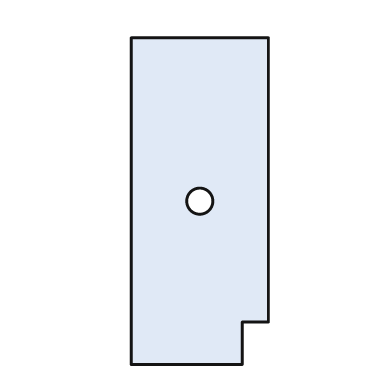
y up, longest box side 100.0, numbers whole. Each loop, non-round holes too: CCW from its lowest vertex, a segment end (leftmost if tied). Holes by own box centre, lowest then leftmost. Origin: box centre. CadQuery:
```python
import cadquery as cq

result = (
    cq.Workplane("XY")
    .moveTo(-21.0, -50.0)
    .lineTo(13.0, -50.0)
    .lineTo(13.0, -37.0)
    .lineTo(21.0, -37.0)
    .lineTo(21.0, 50.0)
    .lineTo(-21.0, 50.0)
    .close()
    .moveTo(0.0, 0.0)
    .circle(4.0)
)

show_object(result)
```